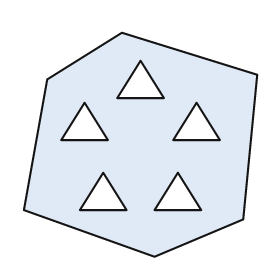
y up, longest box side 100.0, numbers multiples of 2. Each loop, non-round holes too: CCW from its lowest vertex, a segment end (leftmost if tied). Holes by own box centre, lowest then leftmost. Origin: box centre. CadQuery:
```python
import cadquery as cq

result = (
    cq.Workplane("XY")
    .moveTo(6.0, -48.0)
    .lineTo(44.0, -32.0)
    .lineTo(50.0, 30.0)
    .lineTo(-8.0, 48.0)
    .lineTo(-40.0, 28.0)
    .lineTo(-50.0, -28.0)
    .close()
    .moveTo(-26.0, -28.0)
    .lineTo(-6.0, -28.0)
    .lineTo(-16.0, -12.0)
    .close()
    .moveTo(6.0, -28.0)
    .lineTo(26.0, -28.0)
    .lineTo(16.0, -12.0)
    .close()
    .moveTo(-34.0, 2.0)
    .lineTo(-14.0, 2.0)
    .lineTo(-24.0, 18.0)
    .close()
    .moveTo(14.0, 2.0)
    .lineTo(34.0, 2.0)
    .lineTo(24.0, 18.0)
    .close()
    .moveTo(-10.0, 20.0)
    .lineTo(10.0, 20.0)
    .lineTo(0.0, 36.0)
    .close()
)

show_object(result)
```